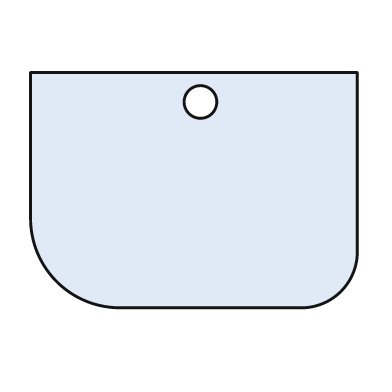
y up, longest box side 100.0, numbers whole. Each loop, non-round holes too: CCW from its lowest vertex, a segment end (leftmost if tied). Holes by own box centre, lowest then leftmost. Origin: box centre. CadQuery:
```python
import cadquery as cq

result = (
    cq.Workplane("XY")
    .moveTo(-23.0, -36.0)
    .lineTo(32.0, -36.0)
    .threePointArc((45.0, -31.0), (50.0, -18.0))
    .lineTo(50.0, 36.0)
    .lineTo(-50.0, 36.0)
    .lineTo(-50.0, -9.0)
    .threePointArc((-42.0, -28.0), (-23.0, -36.0))
    .close()
    .moveTo(2.0, 27.0)
    .circle(5.0)
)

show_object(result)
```